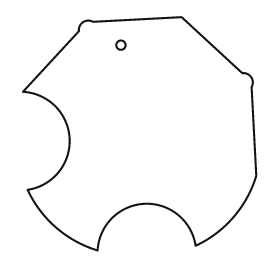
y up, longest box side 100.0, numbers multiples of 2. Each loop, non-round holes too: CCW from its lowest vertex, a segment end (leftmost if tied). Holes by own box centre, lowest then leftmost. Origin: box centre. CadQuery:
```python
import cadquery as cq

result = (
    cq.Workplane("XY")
    .moveTo(-18.0, -50.0)
    .threePointArc((2.0, -30.0), (24.0, -48.0))
    .threePointArc((40.0, -36.0), (50.0, -18.0))
    .lineTo(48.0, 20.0)
    .threePointArc((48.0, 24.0), (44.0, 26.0))
    .lineTo(18.0, 50.0)
    .lineTo(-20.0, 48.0)
    .threePointArc((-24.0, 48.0), (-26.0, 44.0))
    .lineTo(-50.0, 18.0)
    .threePointArc((-30.0, -2.0), (-48.0, -24.0))
    .threePointArc((-36.0, -40.0), (-18.0, -50.0))
    .close()
    .moveTo(-8.0, 38.0)
    .circle(2.0)
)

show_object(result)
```